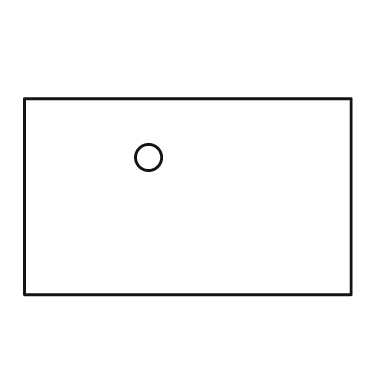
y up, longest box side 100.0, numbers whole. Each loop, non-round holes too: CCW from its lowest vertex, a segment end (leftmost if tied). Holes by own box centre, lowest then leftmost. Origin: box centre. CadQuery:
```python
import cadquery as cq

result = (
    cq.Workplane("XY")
    .moveTo(-50.0, -30.0)
    .lineTo(50.0, -30.0)
    .lineTo(50.0, 30.0)
    .lineTo(-50.0, 30.0)
    .close()
    .moveTo(-12.0, 12.0)
    .circle(4.0)
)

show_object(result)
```